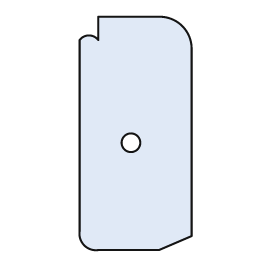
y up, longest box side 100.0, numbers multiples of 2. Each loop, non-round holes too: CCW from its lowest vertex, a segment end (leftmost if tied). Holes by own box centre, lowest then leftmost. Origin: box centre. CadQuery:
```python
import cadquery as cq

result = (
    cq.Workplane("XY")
    .moveTo(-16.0, -50.0)
    .lineTo(10.0, -50.0)
    .lineTo(24.0, -44.0)
    .lineTo(24.0, 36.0)
    .threePointArc((20.0, 46.0), (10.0, 50.0))
    .lineTo(-16.0, 50.0)
    .lineTo(-16.0, 40.0)
    .threePointArc((-20.0, 42.0), (-24.0, 40.0))
    .lineTo(-24.0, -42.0)
    .threePointArc((-22.0, -48.0), (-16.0, -50.0))
    .close()
    .moveTo(-2.0, -4.0)
    .circle(4.0)
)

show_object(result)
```